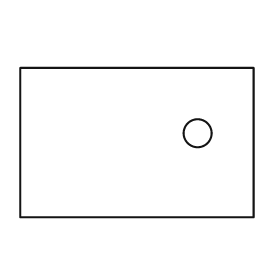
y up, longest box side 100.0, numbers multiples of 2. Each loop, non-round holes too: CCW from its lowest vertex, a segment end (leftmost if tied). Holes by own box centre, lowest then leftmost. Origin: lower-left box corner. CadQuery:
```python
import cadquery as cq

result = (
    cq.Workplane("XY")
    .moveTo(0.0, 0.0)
    .lineTo(100.0, 0.0)
    .lineTo(100.0, 64.0)
    .lineTo(0.0, 64.0)
    .close()
    .moveTo(76.0, 36.0)
    .circle(6.0)
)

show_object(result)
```